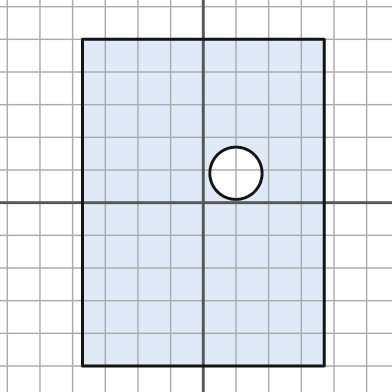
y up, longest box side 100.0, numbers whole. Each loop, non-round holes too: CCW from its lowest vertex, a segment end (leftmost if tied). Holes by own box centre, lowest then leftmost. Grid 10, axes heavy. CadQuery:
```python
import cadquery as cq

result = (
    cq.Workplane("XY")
    .moveTo(-37.0, -50.0)
    .lineTo(37.0, -50.0)
    .lineTo(37.0, 50.0)
    .lineTo(-37.0, 50.0)
    .close()
    .moveTo(10.0, 9.0)
    .circle(8.0)
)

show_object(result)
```